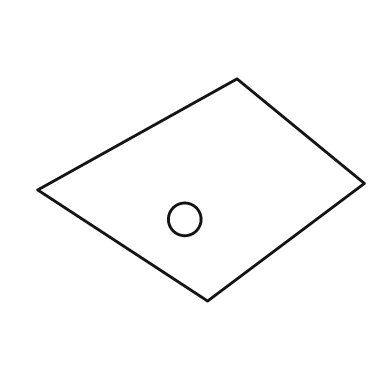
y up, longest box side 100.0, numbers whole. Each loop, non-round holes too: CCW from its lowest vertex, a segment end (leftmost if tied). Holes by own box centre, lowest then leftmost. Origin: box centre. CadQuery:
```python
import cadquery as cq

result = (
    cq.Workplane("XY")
    .moveTo(2.0, -34.0)
    .lineTo(50.0, 2.0)
    .lineTo(11.0, 34.0)
    .lineTo(-50.0, 0.0)
    .close()
    .moveTo(-5.0, -9.0)
    .circle(5.0)
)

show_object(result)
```